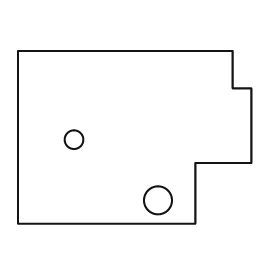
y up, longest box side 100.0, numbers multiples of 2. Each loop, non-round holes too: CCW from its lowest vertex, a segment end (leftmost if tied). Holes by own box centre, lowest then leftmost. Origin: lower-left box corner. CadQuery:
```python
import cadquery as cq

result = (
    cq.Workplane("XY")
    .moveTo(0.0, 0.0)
    .lineTo(76.0, 0.0)
    .lineTo(76.0, 26.0)
    .lineTo(100.0, 26.0)
    .lineTo(100.0, 58.0)
    .lineTo(92.0, 58.0)
    .lineTo(92.0, 74.0)
    .lineTo(0.0, 74.0)
    .close()
    .moveTo(60.0, 10.0)
    .circle(6.0)
    .moveTo(24.0, 36.0)
    .circle(4.0)
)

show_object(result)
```